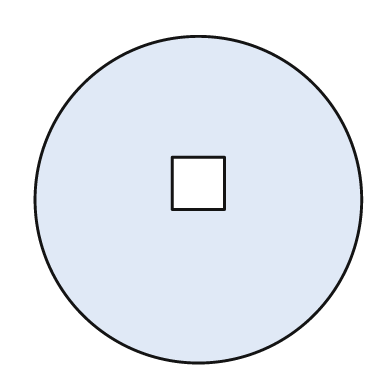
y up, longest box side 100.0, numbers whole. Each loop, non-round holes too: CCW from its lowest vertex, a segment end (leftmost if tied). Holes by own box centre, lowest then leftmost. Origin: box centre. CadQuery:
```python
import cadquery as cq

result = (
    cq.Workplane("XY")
    .moveTo(0.0, 0.0)
    .circle(50.0)
    .moveTo(-8.0, -3.0)
    .lineTo(8.0, -3.0)
    .lineTo(8.0, 13.0)
    .lineTo(-8.0, 13.0)
    .close()
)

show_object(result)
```